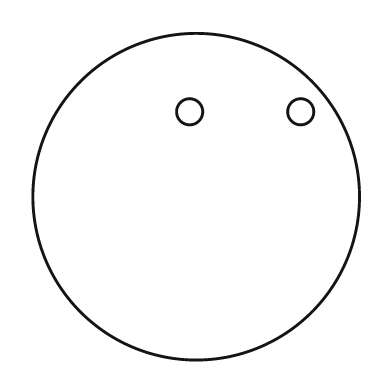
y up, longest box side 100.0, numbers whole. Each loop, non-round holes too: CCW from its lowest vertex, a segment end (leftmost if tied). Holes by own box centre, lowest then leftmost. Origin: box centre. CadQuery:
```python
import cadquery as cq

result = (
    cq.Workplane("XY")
    .moveTo(0.0, 0.0)
    .circle(50.0)
    .moveTo(-2.0, 26.0)
    .circle(4.0)
    .moveTo(32.0, 26.0)
    .circle(4.0)
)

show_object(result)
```